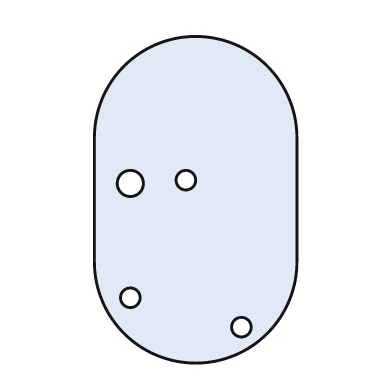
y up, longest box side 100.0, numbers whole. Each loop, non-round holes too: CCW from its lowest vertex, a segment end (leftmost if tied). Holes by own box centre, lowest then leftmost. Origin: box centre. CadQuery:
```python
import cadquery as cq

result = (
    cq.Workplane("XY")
    .moveTo(-31.0, -19.0)
    .threePointArc((0.0, -50.0), (31.0, -19.0))
    .lineTo(31.0, 19.0)
    .threePointArc((0.0, 50.0), (-31.0, 19.0))
    .close()
    .moveTo(14.0, -39.0)
    .circle(3.0)
    .moveTo(-20.0, -30.0)
    .circle(3.0)
    .moveTo(-20.0, 5.0)
    .circle(4.0)
    .moveTo(-3.0, 6.0)
    .circle(3.0)
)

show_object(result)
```